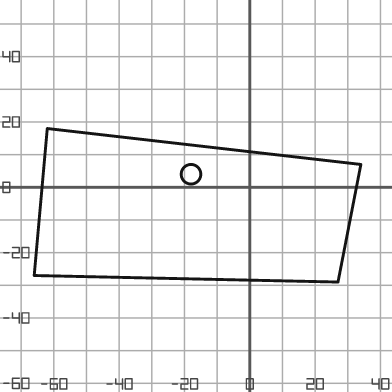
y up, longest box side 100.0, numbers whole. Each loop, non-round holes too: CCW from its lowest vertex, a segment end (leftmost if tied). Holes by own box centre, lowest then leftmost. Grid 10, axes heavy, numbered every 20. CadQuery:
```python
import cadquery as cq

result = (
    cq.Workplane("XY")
    .moveTo(27.0, -29.0)
    .lineTo(34.0, 7.0)
    .lineTo(-62.0, 18.0)
    .lineTo(-66.0, -27.0)
    .close()
    .moveTo(-18.0, 4.0)
    .circle(3.0)
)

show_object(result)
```